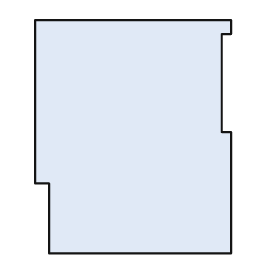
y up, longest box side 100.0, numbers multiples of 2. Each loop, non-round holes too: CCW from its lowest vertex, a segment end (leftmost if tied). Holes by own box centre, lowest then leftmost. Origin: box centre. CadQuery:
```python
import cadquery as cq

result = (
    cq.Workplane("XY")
    .moveTo(-36.0, -50.0)
    .lineTo(42.0, -50.0)
    .lineTo(42.0, 2.0)
    .lineTo(38.0, 2.0)
    .lineTo(38.0, 44.0)
    .lineTo(42.0, 44.0)
    .lineTo(42.0, 50.0)
    .lineTo(-42.0, 50.0)
    .lineTo(-42.0, -20.0)
    .lineTo(-36.0, -20.0)
    .close()
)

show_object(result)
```